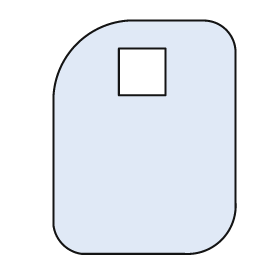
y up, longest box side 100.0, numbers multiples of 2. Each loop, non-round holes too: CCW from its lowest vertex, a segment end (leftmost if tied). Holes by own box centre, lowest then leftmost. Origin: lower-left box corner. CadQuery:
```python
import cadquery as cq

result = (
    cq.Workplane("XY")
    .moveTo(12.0, 0.0)
    .lineTo(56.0, 0.0)
    .threePointArc((72.0, 6.0), (78.0, 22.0))
    .lineTo(78.0, 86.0)
    .threePointArc((74.0, 96.0), (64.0, 100.0))
    .lineTo(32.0, 100.0)
    .threePointArc((10.0, 90.0), (0.0, 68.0))
    .lineTo(0.0, 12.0)
    .threePointArc((4.0, 4.0), (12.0, 0.0))
    .close()
    .moveTo(28.0, 68.0)
    .lineTo(48.0, 68.0)
    .lineTo(48.0, 88.0)
    .lineTo(28.0, 88.0)
    .close()
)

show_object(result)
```